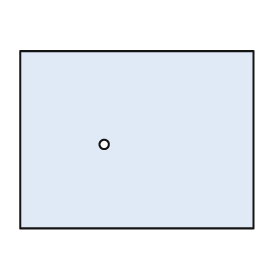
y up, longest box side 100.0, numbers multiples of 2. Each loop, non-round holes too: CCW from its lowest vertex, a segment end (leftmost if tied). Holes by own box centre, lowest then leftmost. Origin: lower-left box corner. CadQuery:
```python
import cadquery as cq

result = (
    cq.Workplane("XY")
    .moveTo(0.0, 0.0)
    .lineTo(100.0, 0.0)
    .lineTo(100.0, 76.0)
    .lineTo(0.0, 76.0)
    .close()
    .moveTo(36.0, 36.0)
    .circle(2.0)
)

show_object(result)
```